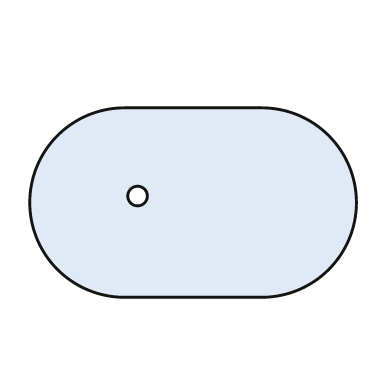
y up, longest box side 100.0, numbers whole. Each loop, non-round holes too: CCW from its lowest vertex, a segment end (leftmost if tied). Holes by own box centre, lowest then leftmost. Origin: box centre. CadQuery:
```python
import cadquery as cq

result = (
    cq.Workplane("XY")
    .moveTo(-21.0, -29.0)
    .lineTo(21.0, -29.0)
    .threePointArc((50.0, 0.0), (21.0, 29.0))
    .lineTo(-21.0, 29.0)
    .threePointArc((-50.0, 0.0), (-21.0, -29.0))
    .close()
    .moveTo(-17.0, 2.0)
    .circle(3.0)
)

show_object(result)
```